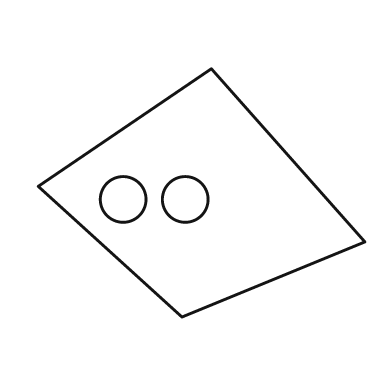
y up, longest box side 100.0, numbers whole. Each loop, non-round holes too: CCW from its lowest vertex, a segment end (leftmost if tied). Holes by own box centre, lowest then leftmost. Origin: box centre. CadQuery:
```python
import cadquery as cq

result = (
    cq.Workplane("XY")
    .moveTo(-6.0, -38.0)
    .lineTo(50.0, -15.0)
    .lineTo(3.0, 38.0)
    .lineTo(-50.0, 2.0)
    .close()
    .moveTo(-24.0, -2.0)
    .circle(7.0)
    .moveTo(-5.0, -2.0)
    .circle(7.0)
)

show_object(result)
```